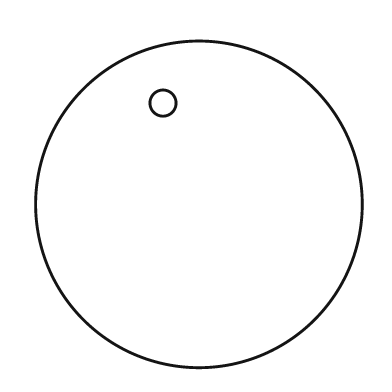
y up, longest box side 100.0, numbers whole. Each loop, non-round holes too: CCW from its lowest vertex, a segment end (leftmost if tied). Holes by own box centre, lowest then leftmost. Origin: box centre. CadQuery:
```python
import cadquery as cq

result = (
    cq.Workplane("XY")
    .moveTo(0.0, 0.0)
    .circle(50.0)
    .moveTo(-11.0, 31.0)
    .circle(4.0)
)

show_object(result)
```